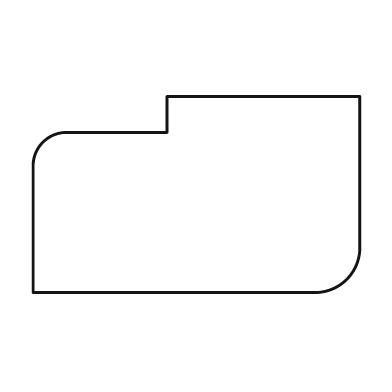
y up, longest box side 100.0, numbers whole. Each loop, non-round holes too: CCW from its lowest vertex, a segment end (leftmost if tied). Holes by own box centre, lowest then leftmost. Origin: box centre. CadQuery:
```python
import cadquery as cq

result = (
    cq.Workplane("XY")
    .moveTo(-50.0, -30.0)
    .lineTo(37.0, -30.0)
    .threePointArc((46.0, -26.0), (50.0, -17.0))
    .lineTo(50.0, 30.0)
    .lineTo(-9.0, 30.0)
    .lineTo(-9.0, 19.0)
    .lineTo(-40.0, 19.0)
    .threePointArc((-47.0, 16.0), (-50.0, 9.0))
    .close()
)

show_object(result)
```